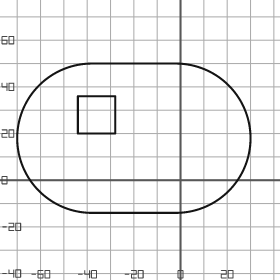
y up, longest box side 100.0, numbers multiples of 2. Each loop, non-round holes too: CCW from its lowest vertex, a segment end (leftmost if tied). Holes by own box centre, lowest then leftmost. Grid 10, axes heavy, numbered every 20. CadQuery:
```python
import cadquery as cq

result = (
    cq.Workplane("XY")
    .moveTo(-38.0, -14.0)
    .lineTo(-2.0, -14.0)
    .threePointArc((30.0, 18.0), (-2.0, 50.0))
    .lineTo(-38.0, 50.0)
    .threePointArc((-70.0, 18.0), (-38.0, -14.0))
    .close()
    .moveTo(-44.0, 20.0)
    .lineTo(-28.0, 20.0)
    .lineTo(-28.0, 36.0)
    .lineTo(-44.0, 36.0)
    .close()
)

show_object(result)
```